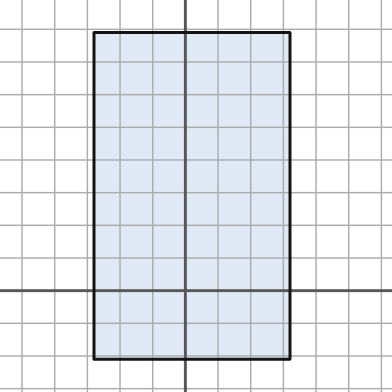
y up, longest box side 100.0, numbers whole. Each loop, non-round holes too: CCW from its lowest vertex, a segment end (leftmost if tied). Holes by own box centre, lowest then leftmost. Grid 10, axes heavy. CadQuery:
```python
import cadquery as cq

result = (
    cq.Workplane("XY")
    .moveTo(-28.0, -21.0)
    .lineTo(32.0, -21.0)
    .lineTo(32.0, 79.0)
    .lineTo(-28.0, 79.0)
    .close()
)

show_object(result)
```